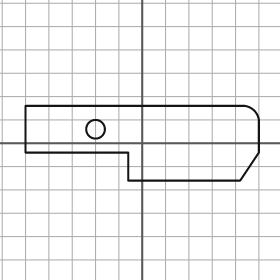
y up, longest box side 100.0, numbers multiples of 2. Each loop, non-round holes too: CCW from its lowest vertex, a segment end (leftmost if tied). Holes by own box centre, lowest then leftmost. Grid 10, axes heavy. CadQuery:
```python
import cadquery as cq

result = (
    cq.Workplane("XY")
    .moveTo(-6.0, -16.0)
    .lineTo(42.0, -16.0)
    .lineTo(50.0, -4.0)
    .lineTo(50.0, 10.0)
    .threePointArc((48.0, 14.0), (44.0, 16.0))
    .lineTo(-50.0, 16.0)
    .lineTo(-50.0, -4.0)
    .lineTo(-6.0, -4.0)
    .close()
    .moveTo(-20.0, 6.0)
    .circle(4.0)
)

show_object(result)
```